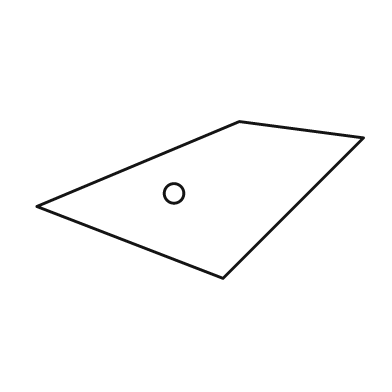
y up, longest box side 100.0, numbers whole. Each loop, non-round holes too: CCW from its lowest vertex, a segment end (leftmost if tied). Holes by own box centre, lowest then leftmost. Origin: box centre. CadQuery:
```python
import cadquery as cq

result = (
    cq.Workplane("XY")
    .moveTo(7.0, -24.0)
    .lineTo(50.0, 19.0)
    .lineTo(12.0, 24.0)
    .lineTo(-50.0, -2.0)
    .close()
    .moveTo(-8.0, 2.0)
    .circle(3.0)
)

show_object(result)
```